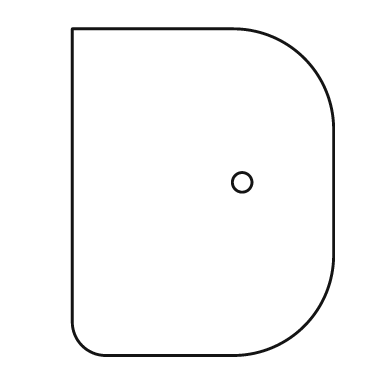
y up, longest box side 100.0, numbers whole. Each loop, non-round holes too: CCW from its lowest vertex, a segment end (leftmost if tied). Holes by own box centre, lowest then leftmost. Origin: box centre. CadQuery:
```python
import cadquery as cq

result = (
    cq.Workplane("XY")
    .moveTo(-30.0, -50.0)
    .lineTo(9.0, -50.0)
    .threePointArc((31.0, -41.0), (40.0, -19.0))
    .lineTo(40.0, 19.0)
    .threePointArc((31.0, 41.0), (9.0, 50.0))
    .lineTo(-40.0, 50.0)
    .lineTo(-40.0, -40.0)
    .threePointArc((-37.0, -47.0), (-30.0, -50.0))
    .close()
    .moveTo(12.0, 3.0)
    .circle(3.0)
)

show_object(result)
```